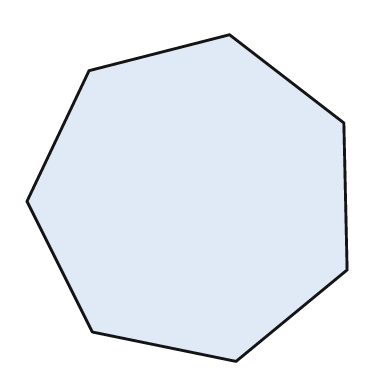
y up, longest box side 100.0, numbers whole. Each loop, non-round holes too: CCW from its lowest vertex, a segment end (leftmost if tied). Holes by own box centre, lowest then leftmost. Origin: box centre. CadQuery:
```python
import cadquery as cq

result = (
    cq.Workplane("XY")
    .moveTo(15.0, -50.0)
    .lineTo(49.0, -22.0)
    .lineTo(48.0, 23.0)
    .lineTo(13.0, 50.0)
    .lineTo(-30.0, 39.0)
    .lineTo(-49.0, -1.0)
    .lineTo(-29.0, -41.0)
    .close()
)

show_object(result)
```